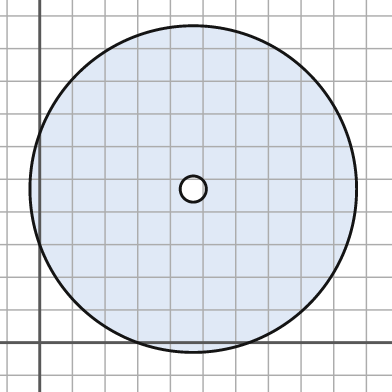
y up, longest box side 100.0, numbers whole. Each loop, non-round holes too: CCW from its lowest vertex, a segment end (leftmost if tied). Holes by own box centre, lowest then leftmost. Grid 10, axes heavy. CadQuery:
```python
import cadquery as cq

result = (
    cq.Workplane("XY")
    .moveTo(47.0, 47.0)
    .circle(50.0)
    .moveTo(47.0, 47.0)
    .circle(4.0)
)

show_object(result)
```